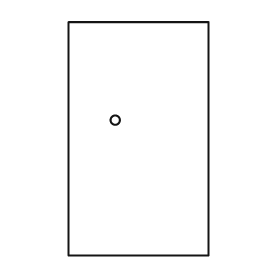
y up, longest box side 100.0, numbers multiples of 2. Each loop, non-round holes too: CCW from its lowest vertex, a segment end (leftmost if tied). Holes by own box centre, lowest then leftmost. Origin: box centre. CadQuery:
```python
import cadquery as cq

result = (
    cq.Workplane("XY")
    .moveTo(-30.0, -50.0)
    .lineTo(30.0, -50.0)
    .lineTo(30.0, 50.0)
    .lineTo(-30.0, 50.0)
    .close()
    .moveTo(-10.0, 8.0)
    .circle(2.0)
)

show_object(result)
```